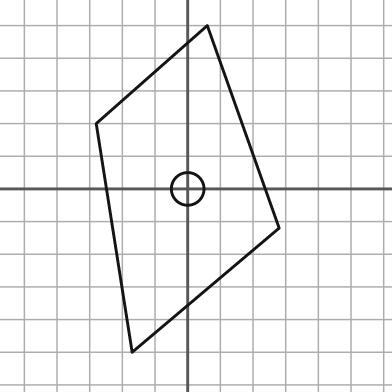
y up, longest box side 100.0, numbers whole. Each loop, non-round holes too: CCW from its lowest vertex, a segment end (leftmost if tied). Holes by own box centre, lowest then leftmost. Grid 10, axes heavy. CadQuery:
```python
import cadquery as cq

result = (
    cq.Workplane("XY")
    .moveTo(-17.0, -50.0)
    .lineTo(28.0, -12.0)
    .lineTo(6.0, 50.0)
    .lineTo(-28.0, 20.0)
    .close()
    .moveTo(0.0, 0.0)
    .circle(5.0)
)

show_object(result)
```